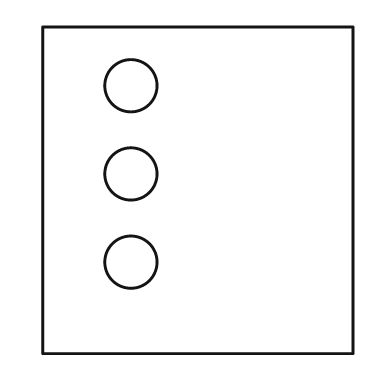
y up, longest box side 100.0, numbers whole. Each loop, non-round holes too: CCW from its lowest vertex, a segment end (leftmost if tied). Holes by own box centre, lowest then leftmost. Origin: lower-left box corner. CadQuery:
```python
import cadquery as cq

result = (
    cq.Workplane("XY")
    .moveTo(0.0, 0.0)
    .lineTo(95.0, 0.0)
    .lineTo(95.0, 100.0)
    .lineTo(0.0, 100.0)
    .close()
    .moveTo(27.0, 28.0)
    .circle(8.0)
    .moveTo(27.0, 55.0)
    .circle(8.0)
    .moveTo(27.0, 82.0)
    .circle(8.0)
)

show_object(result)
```